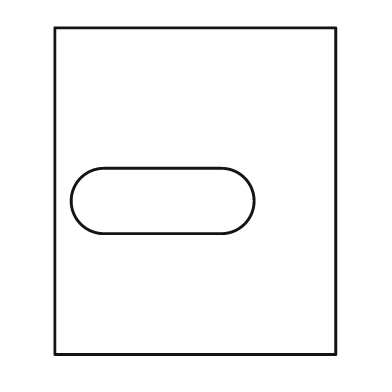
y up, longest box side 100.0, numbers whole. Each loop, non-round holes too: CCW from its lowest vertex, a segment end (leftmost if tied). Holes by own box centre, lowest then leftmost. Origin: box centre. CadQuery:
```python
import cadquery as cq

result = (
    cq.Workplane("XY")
    .moveTo(-43.0, -50.0)
    .lineTo(43.0, -50.0)
    .lineTo(43.0, 50.0)
    .lineTo(-43.0, 50.0)
    .close()
    .moveTo(-28.0, -13.0)
    .lineTo(8.0, -13.0)
    .threePointArc((18.0, -3.0), (8.0, 7.0))
    .lineTo(-28.0, 7.0)
    .threePointArc((-38.0, -3.0), (-28.0, -13.0))
    .close()
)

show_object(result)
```